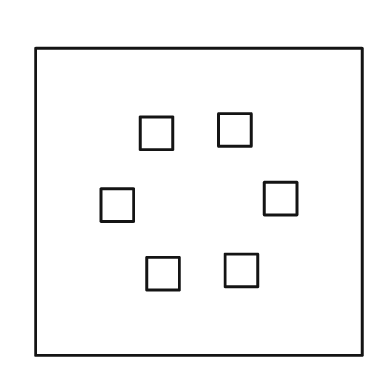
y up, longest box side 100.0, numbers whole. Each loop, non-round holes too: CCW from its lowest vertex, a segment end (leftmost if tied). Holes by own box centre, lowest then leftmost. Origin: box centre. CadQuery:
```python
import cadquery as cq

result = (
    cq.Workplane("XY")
    .moveTo(-50.0, -47.0)
    .lineTo(50.0, -47.0)
    .lineTo(50.0, 47.0)
    .lineTo(-50.0, 47.0)
    .close()
    .moveTo(-16.0, -27.0)
    .lineTo(-6.0, -27.0)
    .lineTo(-6.0, -17.0)
    .lineTo(-16.0, -17.0)
    .close()
    .moveTo(8.0, -26.0)
    .lineTo(18.0, -26.0)
    .lineTo(18.0, -16.0)
    .lineTo(8.0, -16.0)
    .close()
    .moveTo(-30.0, -6.0)
    .lineTo(-20.0, -6.0)
    .lineTo(-20.0, 4.0)
    .lineTo(-30.0, 4.0)
    .close()
    .moveTo(20.0, -4.0)
    .lineTo(30.0, -4.0)
    .lineTo(30.0, 6.0)
    .lineTo(20.0, 6.0)
    .close()
    .moveTo(-18.0, 16.0)
    .lineTo(-8.0, 16.0)
    .lineTo(-8.0, 26.0)
    .lineTo(-18.0, 26.0)
    .close()
    .moveTo(6.0, 17.0)
    .lineTo(16.0, 17.0)
    .lineTo(16.0, 27.0)
    .lineTo(6.0, 27.0)
    .close()
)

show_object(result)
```